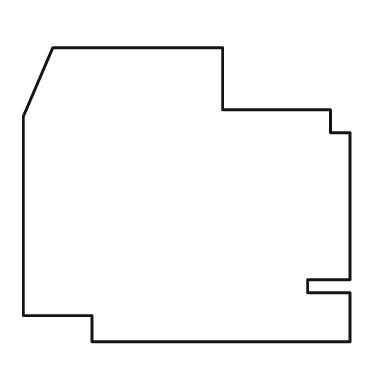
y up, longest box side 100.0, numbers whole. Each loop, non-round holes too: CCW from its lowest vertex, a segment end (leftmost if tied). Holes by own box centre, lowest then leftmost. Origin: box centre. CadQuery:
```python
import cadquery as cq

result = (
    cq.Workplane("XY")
    .moveTo(-29.0, -45.0)
    .lineTo(50.0, -45.0)
    .lineTo(50.0, -30.0)
    .lineTo(37.0, -30.0)
    .lineTo(37.0, -26.0)
    .lineTo(50.0, -26.0)
    .lineTo(50.0, 19.0)
    .lineTo(44.0, 19.0)
    .lineTo(44.0, 26.0)
    .lineTo(11.0, 26.0)
    .lineTo(11.0, 45.0)
    .lineTo(-41.0, 45.0)
    .lineTo(-50.0, 24.0)
    .lineTo(-50.0, -37.0)
    .lineTo(-29.0, -37.0)
    .close()
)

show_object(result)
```